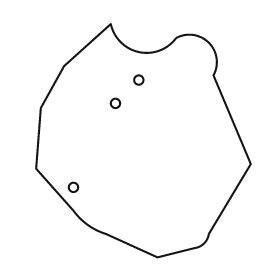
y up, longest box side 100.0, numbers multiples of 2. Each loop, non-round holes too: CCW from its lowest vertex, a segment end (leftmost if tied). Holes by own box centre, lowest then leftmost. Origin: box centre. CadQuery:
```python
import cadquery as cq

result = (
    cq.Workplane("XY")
    .moveTo(6.0, -50.0)
    .lineTo(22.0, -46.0)
    .threePointArc((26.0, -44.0), (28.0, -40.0))
    .lineTo(46.0, -10.0)
    .lineTo(30.0, 28.0)
    .threePointArc((28.0, 42.0), (14.0, 44.0))
    .threePointArc((-2.0, 38.0), (-14.0, 50.0))
    .lineTo(-34.0, 32.0)
    .lineTo(-44.0, 14.0)
    .lineTo(-46.0, -12.0)
    .lineTo(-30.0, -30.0)
    .threePointArc((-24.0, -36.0), (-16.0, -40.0))
    .close()
    .moveTo(-30.0, -20.0)
    .circle(2.0)
    .moveTo(-12.0, 16.0)
    .circle(2.0)
    .moveTo(-2.0, 26.0)
    .circle(2.0)
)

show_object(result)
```